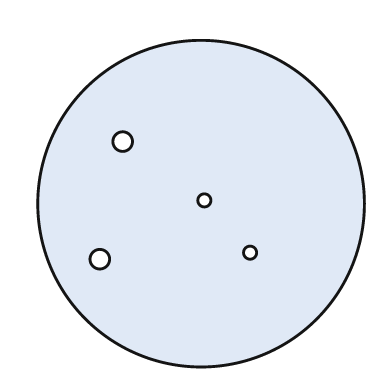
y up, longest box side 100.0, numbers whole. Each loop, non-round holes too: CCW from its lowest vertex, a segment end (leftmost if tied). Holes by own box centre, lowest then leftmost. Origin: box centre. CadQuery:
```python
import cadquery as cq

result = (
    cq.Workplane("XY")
    .moveTo(0.0, 0.0)
    .circle(50.0)
    .moveTo(-31.0, -17.0)
    .circle(3.0)
    .moveTo(15.0, -15.0)
    .circle(2.0)
    .moveTo(1.0, 1.0)
    .circle(2.0)
    .moveTo(-24.0, 19.0)
    .circle(3.0)
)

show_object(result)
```